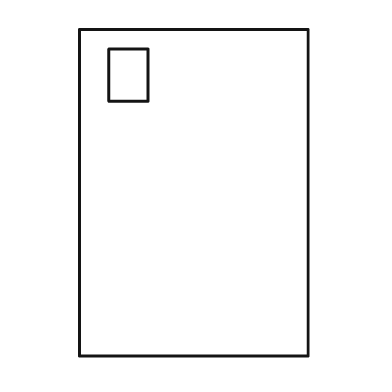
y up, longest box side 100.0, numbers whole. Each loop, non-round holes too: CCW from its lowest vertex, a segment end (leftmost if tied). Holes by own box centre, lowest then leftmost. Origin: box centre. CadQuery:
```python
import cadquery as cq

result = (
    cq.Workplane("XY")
    .moveTo(-35.0, -50.0)
    .lineTo(35.0, -50.0)
    .lineTo(35.0, 50.0)
    .lineTo(-35.0, 50.0)
    .close()
    .moveTo(-26.0, 28.0)
    .lineTo(-14.0, 28.0)
    .lineTo(-14.0, 44.0)
    .lineTo(-26.0, 44.0)
    .close()
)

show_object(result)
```